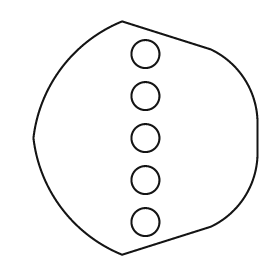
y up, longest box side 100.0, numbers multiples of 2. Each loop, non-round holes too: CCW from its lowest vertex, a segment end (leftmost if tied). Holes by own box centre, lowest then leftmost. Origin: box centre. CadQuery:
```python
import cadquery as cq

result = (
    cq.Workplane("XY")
    .moveTo(-10.0, -50.0)
    .lineTo(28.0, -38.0)
    .threePointArc((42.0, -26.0), (48.0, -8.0))
    .lineTo(48.0, 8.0)
    .threePointArc((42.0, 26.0), (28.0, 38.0))
    .lineTo(-10.0, 50.0)
    .threePointArc((-36.0, 30.0), (-48.0, 0.0))
    .threePointArc((-36.0, -30.0), (-10.0, -50.0))
    .close()
    .moveTo(0.0, -36.0)
    .circle(6.0)
    .moveTo(0.0, -18.0)
    .circle(6.0)
    .moveTo(0.0, 0.0)
    .circle(6.0)
    .moveTo(0.0, 18.0)
    .circle(6.0)
    .moveTo(0.0, 36.0)
    .circle(6.0)
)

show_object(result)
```